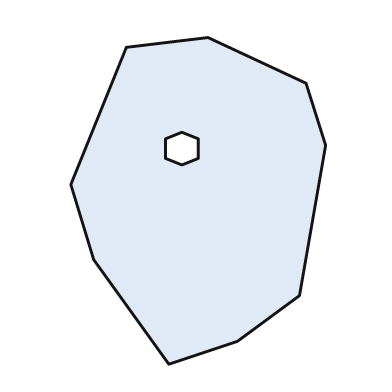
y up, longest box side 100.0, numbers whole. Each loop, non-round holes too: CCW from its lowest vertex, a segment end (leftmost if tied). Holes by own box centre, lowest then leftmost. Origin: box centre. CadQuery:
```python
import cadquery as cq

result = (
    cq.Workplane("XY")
    .moveTo(-9.0, -50.0)
    .lineTo(12.0, -43.0)
    .lineTo(31.0, -29.0)
    .lineTo(39.0, 17.0)
    .lineTo(33.0, 36.0)
    .lineTo(3.0, 50.0)
    .lineTo(-22.0, 47.0)
    .lineTo(-39.0, 5.0)
    .lineTo(-32.0, -18.0)
    .close()
    .moveTo(-5.0, 11.0)
    .lineTo(0.0, 13.0)
    .lineTo(0.0, 19.0)
    .lineTo(-5.0, 21.0)
    .lineTo(-10.0, 19.0)
    .lineTo(-10.0, 13.0)
    .close()
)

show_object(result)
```